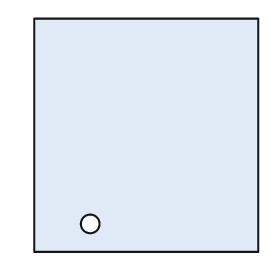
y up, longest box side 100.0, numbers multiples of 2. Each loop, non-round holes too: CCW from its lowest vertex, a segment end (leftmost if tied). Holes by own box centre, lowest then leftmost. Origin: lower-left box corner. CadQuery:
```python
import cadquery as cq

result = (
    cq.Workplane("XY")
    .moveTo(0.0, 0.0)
    .lineTo(96.0, 0.0)
    .lineTo(96.0, 100.0)
    .lineTo(0.0, 100.0)
    .close()
    .moveTo(24.0, 12.0)
    .circle(4.0)
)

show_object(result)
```